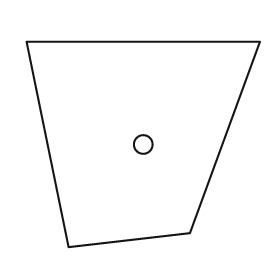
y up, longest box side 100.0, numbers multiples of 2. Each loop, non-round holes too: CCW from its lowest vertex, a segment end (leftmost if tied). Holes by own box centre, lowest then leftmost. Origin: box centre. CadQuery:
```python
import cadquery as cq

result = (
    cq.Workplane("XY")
    .moveTo(-32.0, -44.0)
    .lineTo(20.0, -38.0)
    .lineTo(50.0, 44.0)
    .lineTo(-50.0, 44.0)
    .close()
    .moveTo(0.0, 0.0)
    .circle(4.0)
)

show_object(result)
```